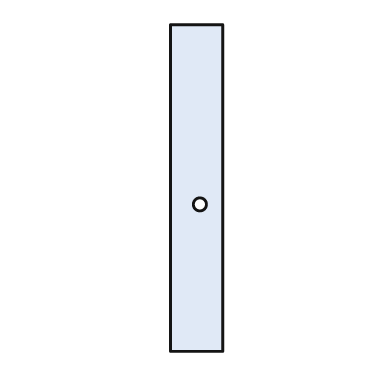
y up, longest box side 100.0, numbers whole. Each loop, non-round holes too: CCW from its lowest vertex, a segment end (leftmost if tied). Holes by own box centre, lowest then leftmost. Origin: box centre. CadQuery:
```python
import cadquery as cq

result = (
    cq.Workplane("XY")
    .moveTo(-8.0, -50.0)
    .lineTo(8.0, -50.0)
    .lineTo(8.0, 50.0)
    .lineTo(-8.0, 50.0)
    .close()
    .moveTo(1.0, -5.0)
    .circle(2.0)
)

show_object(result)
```